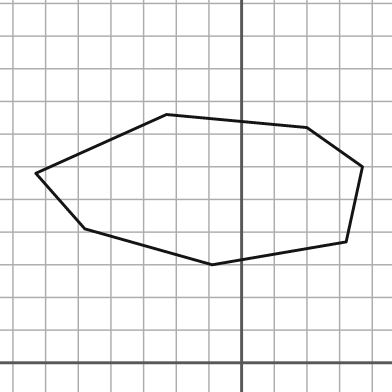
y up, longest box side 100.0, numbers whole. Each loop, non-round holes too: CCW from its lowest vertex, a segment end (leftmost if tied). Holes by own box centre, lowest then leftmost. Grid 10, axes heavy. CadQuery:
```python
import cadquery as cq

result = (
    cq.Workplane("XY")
    .moveTo(-9.0, 30.0)
    .lineTo(32.0, 37.0)
    .lineTo(37.0, 60.0)
    .lineTo(20.0, 72.0)
    .lineTo(-23.0, 76.0)
    .lineTo(-63.0, 58.0)
    .lineTo(-48.0, 41.0)
    .close()
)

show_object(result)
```